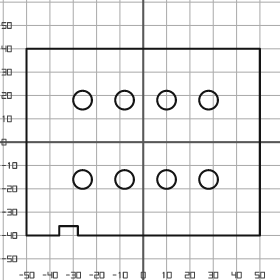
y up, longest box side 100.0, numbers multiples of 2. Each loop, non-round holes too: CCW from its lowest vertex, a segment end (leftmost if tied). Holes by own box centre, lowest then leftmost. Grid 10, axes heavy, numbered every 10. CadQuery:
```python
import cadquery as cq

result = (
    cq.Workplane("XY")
    .moveTo(-50.0, -40.0)
    .lineTo(-36.0, -40.0)
    .lineTo(-36.0, -36.0)
    .lineTo(-28.0, -36.0)
    .lineTo(-28.0, -40.0)
    .lineTo(50.0, -40.0)
    .lineTo(50.0, 40.0)
    .lineTo(-50.0, 40.0)
    .close()
    .moveTo(-26.0, -16.0)
    .circle(4.0)
    .moveTo(-8.0, -16.0)
    .circle(4.0)
    .moveTo(10.0, -16.0)
    .circle(4.0)
    .moveTo(28.0, -16.0)
    .circle(4.0)
    .moveTo(-26.0, 18.0)
    .circle(4.0)
    .moveTo(-8.0, 18.0)
    .circle(4.0)
    .moveTo(10.0, 18.0)
    .circle(4.0)
    .moveTo(28.0, 18.0)
    .circle(4.0)
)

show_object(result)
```